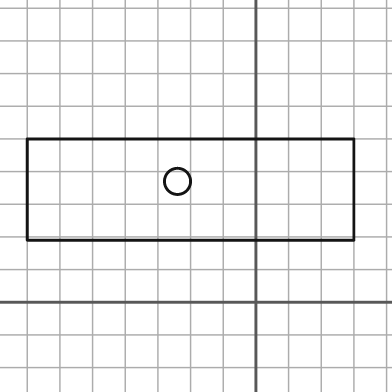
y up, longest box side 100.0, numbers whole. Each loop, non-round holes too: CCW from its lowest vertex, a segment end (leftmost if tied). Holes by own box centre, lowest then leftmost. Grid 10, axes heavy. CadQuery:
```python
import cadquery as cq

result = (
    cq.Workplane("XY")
    .moveTo(-70.0, 19.0)
    .lineTo(30.0, 19.0)
    .lineTo(30.0, 50.0)
    .lineTo(-70.0, 50.0)
    .close()
    .moveTo(-24.0, 37.0)
    .circle(4.0)
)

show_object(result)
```